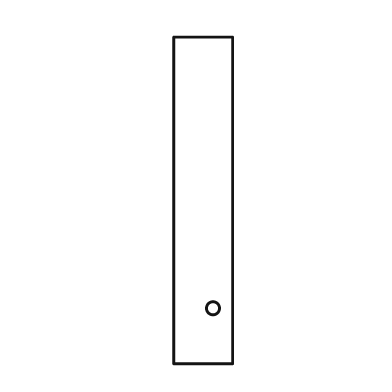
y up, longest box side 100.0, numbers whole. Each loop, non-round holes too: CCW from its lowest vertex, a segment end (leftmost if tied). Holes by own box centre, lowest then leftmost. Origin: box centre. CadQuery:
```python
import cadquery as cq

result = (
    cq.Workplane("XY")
    .moveTo(-9.0, -50.0)
    .lineTo(9.0, -50.0)
    .lineTo(9.0, 50.0)
    .lineTo(-9.0, 50.0)
    .close()
    .moveTo(3.0, -33.0)
    .circle(2.0)
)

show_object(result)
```